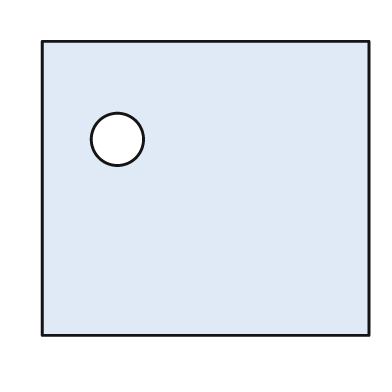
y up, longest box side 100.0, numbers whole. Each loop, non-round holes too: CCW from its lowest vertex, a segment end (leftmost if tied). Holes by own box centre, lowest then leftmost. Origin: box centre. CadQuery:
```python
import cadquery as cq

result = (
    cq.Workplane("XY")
    .moveTo(-50.0, -45.0)
    .lineTo(50.0, -45.0)
    .lineTo(50.0, 45.0)
    .lineTo(-50.0, 45.0)
    .close()
    .moveTo(-27.0, 15.0)
    .circle(8.0)
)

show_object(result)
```